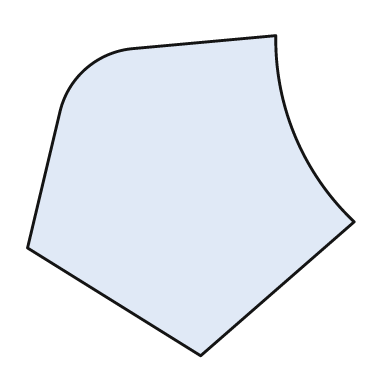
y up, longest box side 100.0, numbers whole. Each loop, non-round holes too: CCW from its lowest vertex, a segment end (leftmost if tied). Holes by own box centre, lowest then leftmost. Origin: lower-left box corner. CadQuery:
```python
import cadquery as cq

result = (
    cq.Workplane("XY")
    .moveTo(53.0, 0.0)
    .lineTo(100.0, 41.0)
    .threePointArc((82.0, 67.0), (76.0, 98.0))
    .lineTo(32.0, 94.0)
    .threePointArc((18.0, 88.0), (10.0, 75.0))
    .lineTo(0.0, 33.0)
    .close()
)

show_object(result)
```